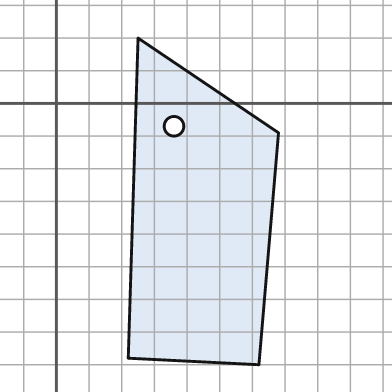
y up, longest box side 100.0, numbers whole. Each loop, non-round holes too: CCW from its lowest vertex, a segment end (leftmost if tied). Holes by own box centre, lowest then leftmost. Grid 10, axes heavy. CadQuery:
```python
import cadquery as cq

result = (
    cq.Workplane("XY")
    .moveTo(62.0, -80.0)
    .lineTo(68.0, -9.0)
    .lineTo(25.0, 20.0)
    .lineTo(22.0, -78.0)
    .close()
    .moveTo(36.0, -7.0)
    .circle(3.0)
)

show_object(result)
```